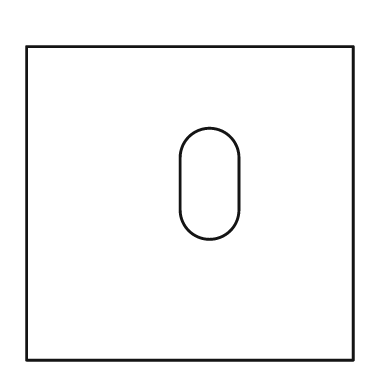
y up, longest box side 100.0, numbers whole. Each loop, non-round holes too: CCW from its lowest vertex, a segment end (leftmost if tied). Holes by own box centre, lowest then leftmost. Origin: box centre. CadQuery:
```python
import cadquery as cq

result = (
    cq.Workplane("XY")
    .moveTo(-50.0, -48.0)
    .lineTo(50.0, -48.0)
    .lineTo(50.0, 48.0)
    .lineTo(-50.0, 48.0)
    .close()
    .moveTo(-3.0, -2.0)
    .threePointArc((6.0, -11.0), (15.0, -2.0))
    .lineTo(15.0, 14.0)
    .threePointArc((6.0, 23.0), (-3.0, 14.0))
    .close()
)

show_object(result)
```